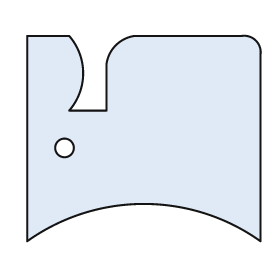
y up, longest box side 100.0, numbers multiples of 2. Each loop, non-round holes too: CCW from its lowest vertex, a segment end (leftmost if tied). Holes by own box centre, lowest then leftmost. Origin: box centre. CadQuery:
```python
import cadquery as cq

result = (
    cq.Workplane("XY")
    .moveTo(-50.0, -44.0)
    .threePointArc((0.0, -28.0), (50.0, -44.0))
    .lineTo(50.0, 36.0)
    .threePointArc((48.0, 42.0), (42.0, 44.0))
    .lineTo(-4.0, 44.0)
    .threePointArc((-12.0, 40.0), (-16.0, 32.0))
    .lineTo(-16.0, 12.0)
    .lineTo(-32.0, 12.0)
    .threePointArc((-26.0, 28.0), (-32.0, 44.0))
    .lineTo(-50.0, 44.0)
    .close()
    .moveTo(-34.0, -4.0)
    .circle(4.0)
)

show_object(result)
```